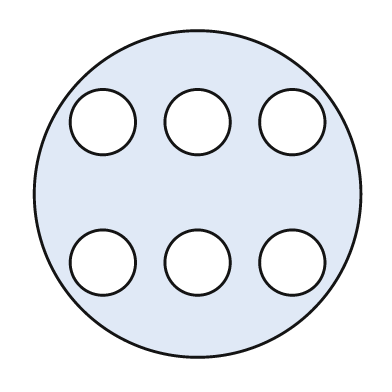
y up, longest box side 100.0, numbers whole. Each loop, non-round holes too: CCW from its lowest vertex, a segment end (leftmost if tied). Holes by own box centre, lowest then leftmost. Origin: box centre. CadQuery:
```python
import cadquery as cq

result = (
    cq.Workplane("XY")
    .moveTo(0.0, 0.0)
    .circle(50.0)
    .moveTo(-29.0, -21.0)
    .circle(10.0)
    .moveTo(0.0, -21.0)
    .circle(10.0)
    .moveTo(29.0, -21.0)
    .circle(10.0)
    .moveTo(-29.0, 22.0)
    .circle(10.0)
    .moveTo(0.0, 22.0)
    .circle(10.0)
    .moveTo(29.0, 22.0)
    .circle(10.0)
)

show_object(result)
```